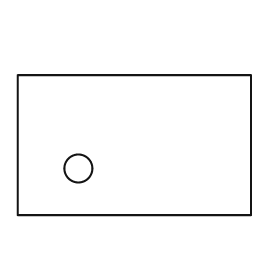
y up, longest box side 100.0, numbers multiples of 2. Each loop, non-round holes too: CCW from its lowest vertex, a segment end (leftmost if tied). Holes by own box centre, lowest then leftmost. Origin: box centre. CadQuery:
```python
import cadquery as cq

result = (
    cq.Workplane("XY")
    .moveTo(-50.0, -30.0)
    .lineTo(50.0, -30.0)
    .lineTo(50.0, 30.0)
    .lineTo(-50.0, 30.0)
    .close()
    .moveTo(-24.0, -10.0)
    .circle(6.0)
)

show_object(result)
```